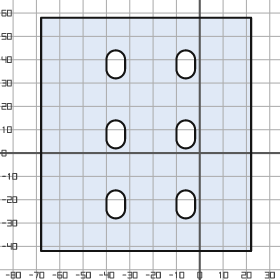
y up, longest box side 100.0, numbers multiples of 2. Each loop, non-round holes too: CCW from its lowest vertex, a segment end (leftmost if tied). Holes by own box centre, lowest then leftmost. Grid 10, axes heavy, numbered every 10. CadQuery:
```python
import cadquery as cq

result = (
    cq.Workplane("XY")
    .moveTo(-68.0, -42.0)
    .lineTo(22.0, -42.0)
    .lineTo(22.0, 58.0)
    .lineTo(-68.0, 58.0)
    .close()
    .moveTo(-40.0, -24.0)
    .threePointArc((-36.0, -28.0), (-32.0, -24.0))
    .lineTo(-32.0, -20.0)
    .threePointArc((-36.0, -16.0), (-40.0, -20.0))
    .close()
    .moveTo(-10.0, -24.0)
    .threePointArc((-6.0, -28.0), (-2.0, -24.0))
    .lineTo(-2.0, -20.0)
    .threePointArc((-6.0, -16.0), (-10.0, -20.0))
    .close()
    .moveTo(-40.0, 6.0)
    .threePointArc((-36.0, 2.0), (-32.0, 6.0))
    .lineTo(-32.0, 10.0)
    .threePointArc((-36.0, 14.0), (-40.0, 10.0))
    .close()
    .moveTo(-10.0, 6.0)
    .threePointArc((-6.0, 2.0), (-2.0, 6.0))
    .lineTo(-2.0, 10.0)
    .threePointArc((-6.0, 14.0), (-10.0, 10.0))
    .close()
    .moveTo(-40.0, 36.0)
    .threePointArc((-36.0, 32.0), (-32.0, 36.0))
    .lineTo(-32.0, 40.0)
    .threePointArc((-36.0, 44.0), (-40.0, 40.0))
    .close()
    .moveTo(-10.0, 36.0)
    .threePointArc((-6.0, 32.0), (-2.0, 36.0))
    .lineTo(-2.0, 40.0)
    .threePointArc((-6.0, 44.0), (-10.0, 40.0))
    .close()
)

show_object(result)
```